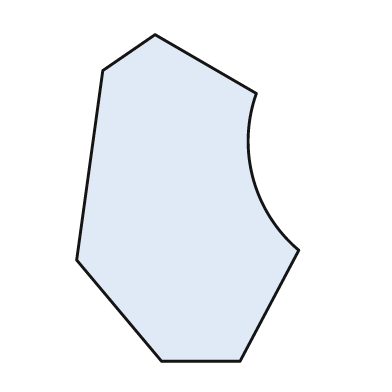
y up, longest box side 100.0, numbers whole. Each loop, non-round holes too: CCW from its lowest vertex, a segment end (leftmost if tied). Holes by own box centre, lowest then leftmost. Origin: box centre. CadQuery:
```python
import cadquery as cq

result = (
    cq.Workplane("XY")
    .moveTo(-8.0, -50.0)
    .lineTo(16.0, -50.0)
    .lineTo(34.0, -16.0)
    .threePointArc((20.0, 6.0), (21.0, 32.0))
    .lineTo(-10.0, 50.0)
    .lineTo(-26.0, 39.0)
    .lineTo(-34.0, -19.0)
    .close()
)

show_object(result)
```